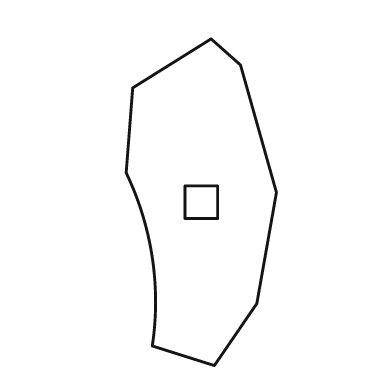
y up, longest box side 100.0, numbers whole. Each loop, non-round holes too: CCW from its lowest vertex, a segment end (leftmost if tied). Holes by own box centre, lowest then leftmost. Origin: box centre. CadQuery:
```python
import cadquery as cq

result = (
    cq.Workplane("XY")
    .moveTo(4.0, -50.0)
    .lineTo(17.0, -31.0)
    .lineTo(23.0, 3.0)
    .lineTo(12.0, 42.0)
    .lineTo(3.0, 50.0)
    .lineTo(-21.0, 35.0)
    .lineTo(-23.0, 9.0)
    .threePointArc((-15.0, -17.0), (-15.0, -44.0))
    .close()
    .moveTo(-5.0, -5.0)
    .lineTo(5.0, -5.0)
    .lineTo(5.0, 5.0)
    .lineTo(-5.0, 5.0)
    .close()
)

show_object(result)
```